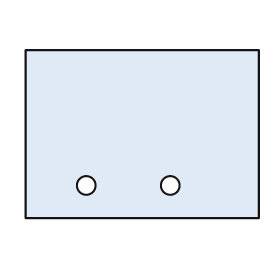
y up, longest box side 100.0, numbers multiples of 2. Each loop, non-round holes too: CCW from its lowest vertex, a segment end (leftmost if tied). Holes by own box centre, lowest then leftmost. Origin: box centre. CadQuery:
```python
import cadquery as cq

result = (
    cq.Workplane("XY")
    .moveTo(-50.0, -36.0)
    .lineTo(50.0, -36.0)
    .lineTo(50.0, 36.0)
    .lineTo(-50.0, 36.0)
    .close()
    .moveTo(-24.0, -22.0)
    .circle(4.0)
    .moveTo(12.0, -22.0)
    .circle(4.0)
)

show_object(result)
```